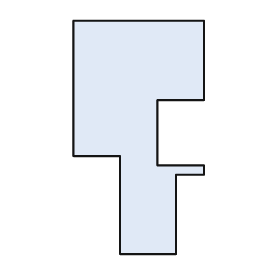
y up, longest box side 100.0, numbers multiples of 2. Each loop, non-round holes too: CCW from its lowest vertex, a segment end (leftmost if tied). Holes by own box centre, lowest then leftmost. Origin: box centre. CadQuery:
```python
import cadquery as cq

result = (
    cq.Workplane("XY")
    .moveTo(-8.0, -50.0)
    .lineTo(16.0, -50.0)
    .lineTo(16.0, -16.0)
    .lineTo(28.0, -16.0)
    .lineTo(28.0, -12.0)
    .lineTo(8.0, -12.0)
    .lineTo(8.0, 16.0)
    .lineTo(28.0, 16.0)
    .lineTo(28.0, 50.0)
    .lineTo(-28.0, 50.0)
    .lineTo(-28.0, -8.0)
    .lineTo(-8.0, -8.0)
    .close()
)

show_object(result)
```